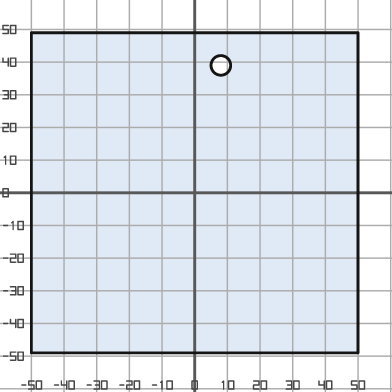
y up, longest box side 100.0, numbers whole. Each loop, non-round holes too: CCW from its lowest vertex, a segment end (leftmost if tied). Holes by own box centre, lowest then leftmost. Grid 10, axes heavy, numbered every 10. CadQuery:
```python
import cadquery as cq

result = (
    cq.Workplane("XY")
    .moveTo(-50.0, -49.0)
    .lineTo(50.0, -49.0)
    .lineTo(50.0, 49.0)
    .lineTo(-50.0, 49.0)
    .close()
    .moveTo(8.0, 39.0)
    .circle(3.0)
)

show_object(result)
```